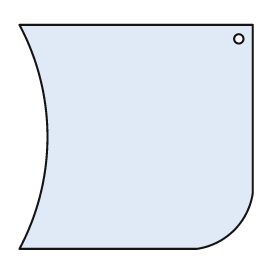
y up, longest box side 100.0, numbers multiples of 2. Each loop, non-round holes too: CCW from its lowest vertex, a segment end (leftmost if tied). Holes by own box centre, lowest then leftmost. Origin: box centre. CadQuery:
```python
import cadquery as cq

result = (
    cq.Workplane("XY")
    .moveTo(-50.0, -48.0)
    .lineTo(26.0, -48.0)
    .threePointArc((42.0, -40.0), (50.0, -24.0))
    .lineTo(50.0, 48.0)
    .lineTo(-50.0, 48.0)
    .threePointArc((-38.0, 0.0), (-50.0, -48.0))
    .close()
    .moveTo(44.0, 42.0)
    .circle(2.0)
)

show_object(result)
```